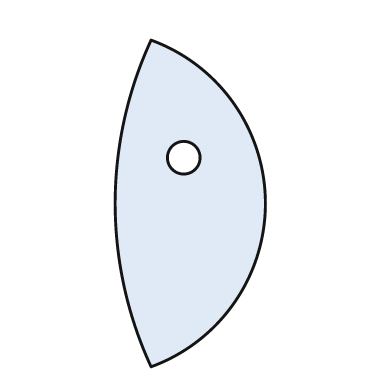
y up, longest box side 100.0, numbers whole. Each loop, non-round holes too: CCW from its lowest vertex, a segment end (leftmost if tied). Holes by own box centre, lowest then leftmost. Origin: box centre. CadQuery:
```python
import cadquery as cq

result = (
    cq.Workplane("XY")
    .moveTo(-12.0, -50.0)
    .threePointArc((23.0, 0.0), (-12.0, 50.0))
    .threePointArc((-23.0, 0.0), (-12.0, -50.0))
    .close()
    .moveTo(-2.0, 14.0)
    .circle(5.0)
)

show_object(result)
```